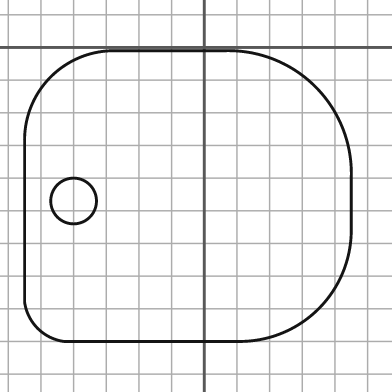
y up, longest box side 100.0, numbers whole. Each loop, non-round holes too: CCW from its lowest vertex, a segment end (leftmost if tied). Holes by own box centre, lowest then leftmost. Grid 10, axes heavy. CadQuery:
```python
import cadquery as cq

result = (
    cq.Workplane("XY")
    .moveTo(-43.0, -90.0)
    .lineTo(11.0, -90.0)
    .threePointArc((35.0, -80.0), (45.0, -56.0))
    .lineTo(45.0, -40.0)
    .threePointArc((34.0, -12.0), (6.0, -1.0))
    .lineTo(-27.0, -1.0)
    .threePointArc((-47.0, -9.0), (-55.0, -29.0))
    .lineTo(-55.0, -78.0)
    .threePointArc((-51.0, -86.0), (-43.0, -90.0))
    .close()
    .moveTo(-40.0, -47.0)
    .circle(7.0)
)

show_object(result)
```